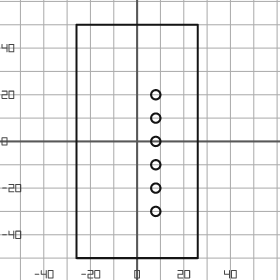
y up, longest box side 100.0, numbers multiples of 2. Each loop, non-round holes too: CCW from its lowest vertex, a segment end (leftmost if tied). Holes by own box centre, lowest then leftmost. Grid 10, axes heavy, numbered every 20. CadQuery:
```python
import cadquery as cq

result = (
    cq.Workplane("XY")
    .moveTo(-26.0, -50.0)
    .lineTo(26.0, -50.0)
    .lineTo(26.0, 50.0)
    .lineTo(-26.0, 50.0)
    .close()
    .moveTo(8.0, -30.0)
    .circle(2.0)
    .moveTo(8.0, -20.0)
    .circle(2.0)
    .moveTo(8.0, -10.0)
    .circle(2.0)
    .moveTo(8.0, 0.0)
    .circle(2.0)
    .moveTo(8.0, 10.0)
    .circle(2.0)
    .moveTo(8.0, 20.0)
    .circle(2.0)
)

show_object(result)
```